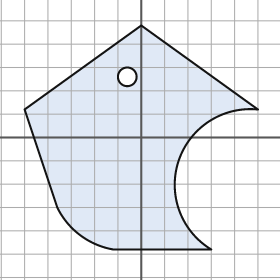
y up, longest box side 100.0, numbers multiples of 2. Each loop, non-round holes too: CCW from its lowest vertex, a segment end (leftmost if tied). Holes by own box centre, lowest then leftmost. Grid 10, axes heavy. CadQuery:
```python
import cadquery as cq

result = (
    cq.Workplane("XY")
    .moveTo(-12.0, -48.0)
    .lineTo(30.0, -48.0)
    .threePointArc((16.0, -10.0), (50.0, 12.0))
    .lineTo(0.0, 48.0)
    .lineTo(-50.0, 12.0)
    .lineTo(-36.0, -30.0)
    .threePointArc((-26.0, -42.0), (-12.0, -48.0))
    .close()
    .moveTo(-6.0, 26.0)
    .circle(4.0)
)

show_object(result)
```